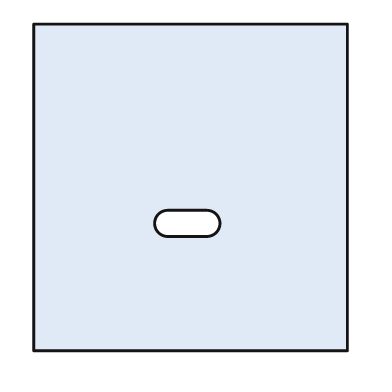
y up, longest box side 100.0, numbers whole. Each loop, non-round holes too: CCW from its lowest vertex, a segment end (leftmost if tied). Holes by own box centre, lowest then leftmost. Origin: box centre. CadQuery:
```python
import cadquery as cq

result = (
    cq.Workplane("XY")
    .moveTo(-48.0, -50.0)
    .lineTo(48.0, -50.0)
    .lineTo(48.0, 50.0)
    .lineTo(-48.0, 50.0)
    .close()
    .moveTo(-7.0, -15.0)
    .lineTo(5.0, -15.0)
    .threePointArc((9.0, -11.0), (5.0, -7.0))
    .lineTo(-7.0, -7.0)
    .threePointArc((-11.0, -11.0), (-7.0, -15.0))
    .close()
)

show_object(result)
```